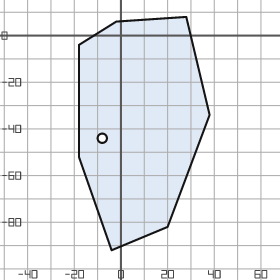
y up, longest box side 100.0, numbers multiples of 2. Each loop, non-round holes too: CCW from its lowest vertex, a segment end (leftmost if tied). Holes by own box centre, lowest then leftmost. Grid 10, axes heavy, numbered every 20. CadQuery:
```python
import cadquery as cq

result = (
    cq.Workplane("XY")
    .moveTo(-4.0, -92.0)
    .lineTo(20.0, -82.0)
    .lineTo(38.0, -34.0)
    .lineTo(28.0, 8.0)
    .lineTo(-2.0, 6.0)
    .lineTo(-18.0, -4.0)
    .lineTo(-18.0, -52.0)
    .close()
    .moveTo(-8.0, -44.0)
    .circle(2.0)
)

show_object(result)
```